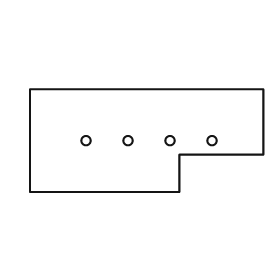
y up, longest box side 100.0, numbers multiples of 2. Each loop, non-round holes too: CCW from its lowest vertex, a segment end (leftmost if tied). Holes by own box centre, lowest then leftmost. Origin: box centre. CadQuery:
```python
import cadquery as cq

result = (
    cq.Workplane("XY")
    .moveTo(-50.0, -22.0)
    .lineTo(14.0, -22.0)
    .lineTo(14.0, -6.0)
    .lineTo(50.0, -6.0)
    .lineTo(50.0, 22.0)
    .lineTo(-50.0, 22.0)
    .close()
    .moveTo(-26.0, 0.0)
    .circle(2.0)
    .moveTo(-8.0, 0.0)
    .circle(2.0)
    .moveTo(10.0, 0.0)
    .circle(2.0)
    .moveTo(28.0, 0.0)
    .circle(2.0)
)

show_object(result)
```